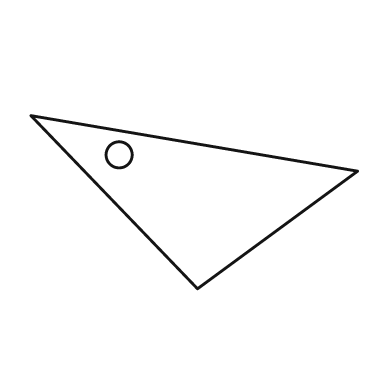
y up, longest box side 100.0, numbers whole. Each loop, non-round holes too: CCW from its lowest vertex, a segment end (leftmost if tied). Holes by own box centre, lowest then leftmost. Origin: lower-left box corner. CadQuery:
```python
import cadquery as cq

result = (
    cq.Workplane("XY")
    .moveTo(51.0, 0.0)
    .lineTo(100.0, 36.0)
    .lineTo(0.0, 53.0)
    .close()
    .moveTo(27.0, 41.0)
    .circle(4.0)
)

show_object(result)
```